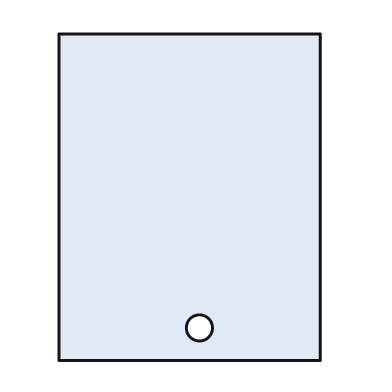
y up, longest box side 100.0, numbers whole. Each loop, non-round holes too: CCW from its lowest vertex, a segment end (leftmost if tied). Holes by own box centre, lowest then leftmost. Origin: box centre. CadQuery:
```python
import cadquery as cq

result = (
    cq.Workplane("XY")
    .moveTo(-40.0, -50.0)
    .lineTo(40.0, -50.0)
    .lineTo(40.0, 50.0)
    .lineTo(-40.0, 50.0)
    .close()
    .moveTo(3.0, -40.0)
    .circle(4.0)
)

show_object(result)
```